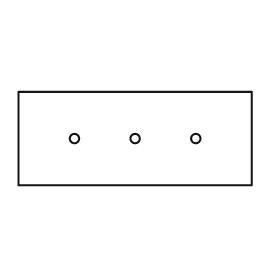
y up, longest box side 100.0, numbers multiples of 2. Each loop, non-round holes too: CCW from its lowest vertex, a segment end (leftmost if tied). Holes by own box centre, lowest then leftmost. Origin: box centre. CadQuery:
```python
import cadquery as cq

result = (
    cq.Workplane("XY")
    .moveTo(-50.0, -20.0)
    .lineTo(50.0, -20.0)
    .lineTo(50.0, 20.0)
    .lineTo(-50.0, 20.0)
    .close()
    .moveTo(-26.0, 0.0)
    .circle(2.0)
    .moveTo(0.0, 0.0)
    .circle(2.0)
    .moveTo(26.0, 0.0)
    .circle(2.0)
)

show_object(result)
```